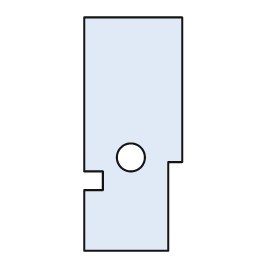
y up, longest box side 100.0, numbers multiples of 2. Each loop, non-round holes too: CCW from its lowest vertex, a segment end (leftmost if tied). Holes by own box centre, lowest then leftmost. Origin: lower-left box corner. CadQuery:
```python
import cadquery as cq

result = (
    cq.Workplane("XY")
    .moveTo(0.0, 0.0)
    .lineTo(36.0, 0.0)
    .lineTo(36.0, 38.0)
    .lineTo(42.0, 38.0)
    .lineTo(42.0, 100.0)
    .lineTo(0.0, 100.0)
    .lineTo(0.0, 34.0)
    .lineTo(8.0, 34.0)
    .lineTo(8.0, 26.0)
    .lineTo(0.0, 26.0)
    .close()
    .moveTo(20.0, 40.0)
    .circle(6.0)
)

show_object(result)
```